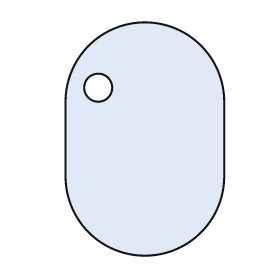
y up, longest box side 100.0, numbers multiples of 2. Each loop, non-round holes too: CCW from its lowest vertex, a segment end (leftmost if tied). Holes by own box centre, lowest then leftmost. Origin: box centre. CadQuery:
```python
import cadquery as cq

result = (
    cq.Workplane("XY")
    .moveTo(-34.0, -16.0)
    .threePointArc((0.0, -50.0), (34.0, -16.0))
    .lineTo(34.0, 16.0)
    .threePointArc((0.0, 50.0), (-34.0, 16.0))
    .close()
    .moveTo(-20.0, 22.0)
    .circle(6.0)
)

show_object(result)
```